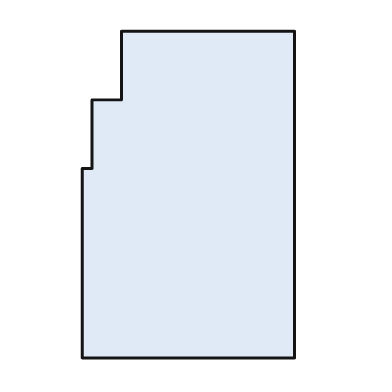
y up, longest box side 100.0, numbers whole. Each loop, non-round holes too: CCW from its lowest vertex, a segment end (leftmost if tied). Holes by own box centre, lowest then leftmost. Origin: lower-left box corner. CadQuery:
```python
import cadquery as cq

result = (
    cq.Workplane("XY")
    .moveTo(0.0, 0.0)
    .lineTo(65.0, 0.0)
    .lineTo(65.0, 100.0)
    .lineTo(12.0, 100.0)
    .lineTo(12.0, 79.0)
    .lineTo(3.0, 79.0)
    .lineTo(3.0, 58.0)
    .lineTo(0.0, 58.0)
    .close()
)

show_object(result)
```